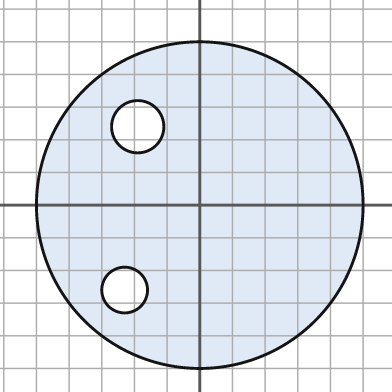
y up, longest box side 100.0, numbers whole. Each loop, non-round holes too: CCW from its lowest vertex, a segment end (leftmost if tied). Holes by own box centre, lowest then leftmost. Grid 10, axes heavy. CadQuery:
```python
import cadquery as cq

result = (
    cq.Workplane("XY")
    .moveTo(0.0, 0.0)
    .circle(50.0)
    .moveTo(-23.0, -26.0)
    .circle(7.0)
    .moveTo(-19.0, 24.0)
    .circle(8.0)
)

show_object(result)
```